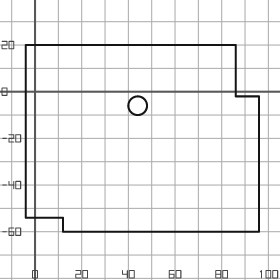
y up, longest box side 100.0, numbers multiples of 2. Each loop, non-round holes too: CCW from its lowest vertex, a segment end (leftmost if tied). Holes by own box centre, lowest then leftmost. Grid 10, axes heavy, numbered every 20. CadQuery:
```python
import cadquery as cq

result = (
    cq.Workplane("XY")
    .moveTo(12.0, -60.0)
    .lineTo(96.0, -60.0)
    .lineTo(96.0, -2.0)
    .lineTo(86.0, -2.0)
    .lineTo(86.0, 20.0)
    .lineTo(-4.0, 20.0)
    .lineTo(-4.0, -54.0)
    .lineTo(12.0, -54.0)
    .close()
    .moveTo(44.0, -6.0)
    .circle(4.0)
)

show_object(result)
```